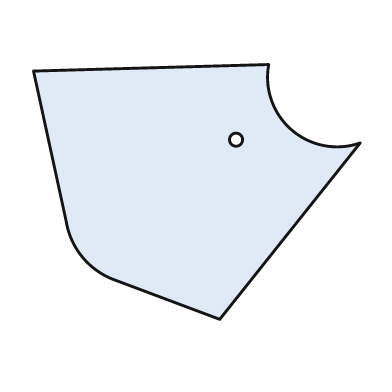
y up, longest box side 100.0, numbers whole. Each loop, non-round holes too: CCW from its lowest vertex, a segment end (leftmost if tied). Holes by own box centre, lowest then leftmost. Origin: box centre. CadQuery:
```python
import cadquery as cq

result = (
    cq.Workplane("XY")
    .moveTo(7.0, -39.0)
    .lineTo(50.0, 15.0)
    .threePointArc((29.0, 19.0), (22.0, 39.0))
    .lineTo(-50.0, 37.0)
    .lineTo(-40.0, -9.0)
    .threePointArc((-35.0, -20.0), (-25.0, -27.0))
    .close()
    .moveTo(12.0, 16.0)
    .circle(2.0)
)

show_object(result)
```